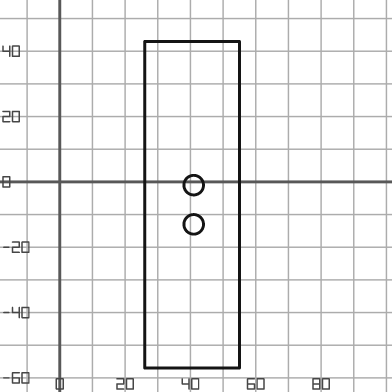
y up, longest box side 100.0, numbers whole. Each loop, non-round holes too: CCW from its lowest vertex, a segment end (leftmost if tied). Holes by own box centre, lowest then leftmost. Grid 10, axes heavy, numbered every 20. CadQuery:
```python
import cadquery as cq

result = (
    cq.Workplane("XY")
    .moveTo(26.0, -57.0)
    .lineTo(55.0, -57.0)
    .lineTo(55.0, 43.0)
    .lineTo(26.0, 43.0)
    .close()
    .moveTo(41.0, -13.0)
    .circle(3.0)
    .moveTo(41.0, -1.0)
    .circle(3.0)
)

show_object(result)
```